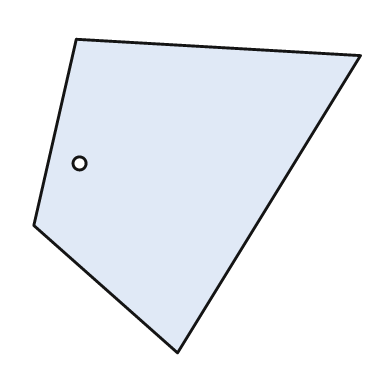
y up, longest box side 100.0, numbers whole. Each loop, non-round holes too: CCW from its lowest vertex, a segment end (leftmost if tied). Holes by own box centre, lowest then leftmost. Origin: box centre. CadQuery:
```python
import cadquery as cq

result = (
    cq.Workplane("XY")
    .moveTo(-6.0, -48.0)
    .lineTo(50.0, 43.0)
    .lineTo(-37.0, 48.0)
    .lineTo(-50.0, -9.0)
    .close()
    .moveTo(-36.0, 10.0)
    .circle(2.0)
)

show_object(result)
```